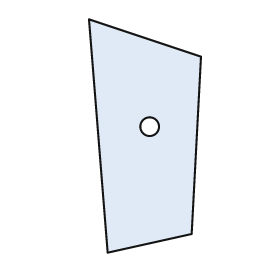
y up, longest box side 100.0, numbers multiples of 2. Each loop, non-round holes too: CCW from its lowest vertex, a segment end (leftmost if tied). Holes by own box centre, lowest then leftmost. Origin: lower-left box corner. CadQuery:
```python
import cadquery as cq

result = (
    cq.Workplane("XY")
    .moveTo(8.0, 0.0)
    .lineTo(44.0, 8.0)
    .lineTo(48.0, 84.0)
    .lineTo(0.0, 100.0)
    .close()
    .moveTo(26.0, 54.0)
    .circle(4.0)
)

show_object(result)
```